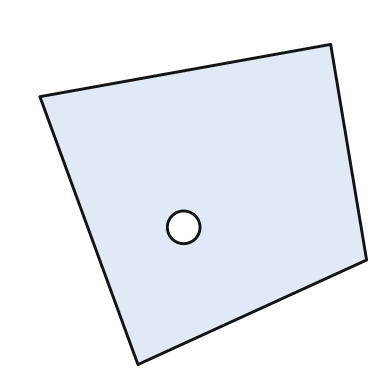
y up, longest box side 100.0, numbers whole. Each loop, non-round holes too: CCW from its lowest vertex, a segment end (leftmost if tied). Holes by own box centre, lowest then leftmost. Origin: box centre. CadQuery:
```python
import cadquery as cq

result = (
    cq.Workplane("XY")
    .moveTo(-20.0, -49.0)
    .lineTo(50.0, -17.0)
    .lineTo(39.0, 49.0)
    .lineTo(-50.0, 33.0)
    .close()
    .moveTo(-6.0, -7.0)
    .circle(5.0)
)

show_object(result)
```